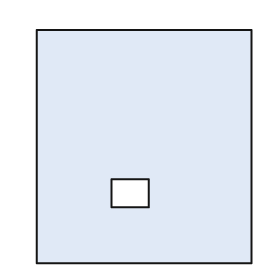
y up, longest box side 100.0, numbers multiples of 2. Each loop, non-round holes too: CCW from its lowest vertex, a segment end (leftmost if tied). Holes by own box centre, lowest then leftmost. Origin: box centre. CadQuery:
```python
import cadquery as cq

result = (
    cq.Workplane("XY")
    .moveTo(-46.0, -50.0)
    .lineTo(46.0, -50.0)
    .lineTo(46.0, 50.0)
    .lineTo(-46.0, 50.0)
    .close()
    .moveTo(-14.0, -26.0)
    .lineTo(2.0, -26.0)
    .lineTo(2.0, -14.0)
    .lineTo(-14.0, -14.0)
    .close()
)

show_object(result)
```